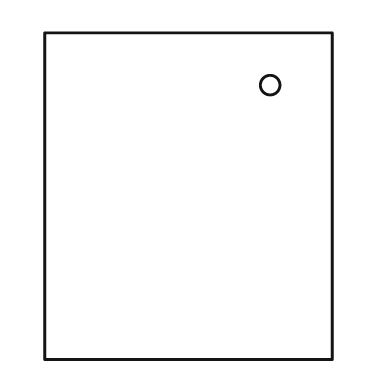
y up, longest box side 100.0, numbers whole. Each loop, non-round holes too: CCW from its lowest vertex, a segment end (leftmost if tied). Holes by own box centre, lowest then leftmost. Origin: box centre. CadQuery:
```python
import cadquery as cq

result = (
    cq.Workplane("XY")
    .moveTo(-44.0, -50.0)
    .lineTo(44.0, -50.0)
    .lineTo(44.0, 50.0)
    .lineTo(-44.0, 50.0)
    .close()
    .moveTo(25.0, 34.0)
    .circle(3.0)
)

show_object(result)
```